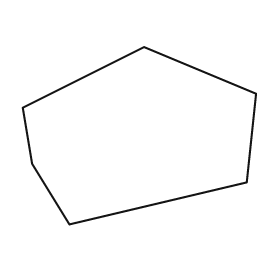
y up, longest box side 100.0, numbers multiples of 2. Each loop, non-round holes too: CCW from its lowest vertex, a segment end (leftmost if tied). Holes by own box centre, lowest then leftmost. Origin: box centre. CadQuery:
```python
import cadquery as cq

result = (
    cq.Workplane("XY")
    .moveTo(-30.0, -38.0)
    .lineTo(46.0, -20.0)
    .lineTo(50.0, 18.0)
    .lineTo(2.0, 38.0)
    .lineTo(-50.0, 12.0)
    .lineTo(-46.0, -12.0)
    .close()
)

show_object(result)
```